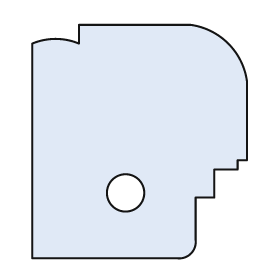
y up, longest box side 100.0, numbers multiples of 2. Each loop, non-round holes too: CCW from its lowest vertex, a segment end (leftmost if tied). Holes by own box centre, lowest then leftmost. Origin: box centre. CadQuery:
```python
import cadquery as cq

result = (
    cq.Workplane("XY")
    .moveTo(-46.0, -50.0)
    .lineTo(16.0, -50.0)
    .threePointArc((22.0, -48.0), (24.0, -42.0))
    .lineTo(24.0, -24.0)
    .lineTo(32.0, -24.0)
    .lineTo(32.0, -12.0)
    .lineTo(42.0, -12.0)
    .lineTo(42.0, -8.0)
    .lineTo(46.0, -8.0)
    .lineTo(46.0, 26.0)
    .threePointArc((38.0, 42.0), (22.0, 50.0))
    .lineTo(-26.0, 50.0)
    .lineTo(-26.0, 42.0)
    .threePointArc((-36.0, 44.0), (-46.0, 42.0))
    .close()
    .moveTo(-6.0, -22.0)
    .circle(8.0)
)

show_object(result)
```